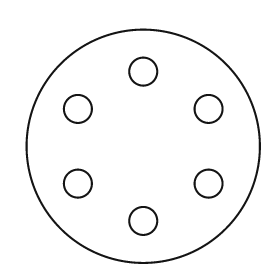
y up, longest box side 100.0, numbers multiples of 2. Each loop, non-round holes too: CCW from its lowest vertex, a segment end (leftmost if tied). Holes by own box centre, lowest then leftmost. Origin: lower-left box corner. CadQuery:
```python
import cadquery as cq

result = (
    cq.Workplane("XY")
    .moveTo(50.0, 50.0)
    .circle(50.0)
    .moveTo(50.0, 18.0)
    .circle(6.0)
    .moveTo(22.0, 34.0)
    .circle(6.0)
    .moveTo(78.0, 34.0)
    .circle(6.0)
    .moveTo(22.0, 66.0)
    .circle(6.0)
    .moveTo(78.0, 66.0)
    .circle(6.0)
    .moveTo(50.0, 82.0)
    .circle(6.0)
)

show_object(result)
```